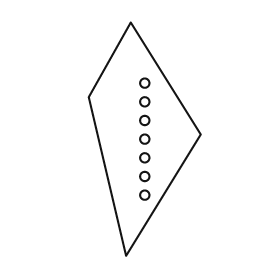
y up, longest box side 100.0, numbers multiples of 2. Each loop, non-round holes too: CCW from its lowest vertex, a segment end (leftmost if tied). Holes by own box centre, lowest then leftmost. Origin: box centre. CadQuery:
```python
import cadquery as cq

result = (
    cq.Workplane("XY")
    .moveTo(-8.0, -50.0)
    .lineTo(24.0, 2.0)
    .lineTo(-6.0, 50.0)
    .lineTo(-24.0, 18.0)
    .close()
    .moveTo(0.0, -24.0)
    .circle(2.0)
    .moveTo(0.0, -16.0)
    .circle(2.0)
    .moveTo(0.0, -8.0)
    .circle(2.0)
    .moveTo(0.0, 0.0)
    .circle(2.0)
    .moveTo(0.0, 8.0)
    .circle(2.0)
    .moveTo(0.0, 16.0)
    .circle(2.0)
    .moveTo(0.0, 24.0)
    .circle(2.0)
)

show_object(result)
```